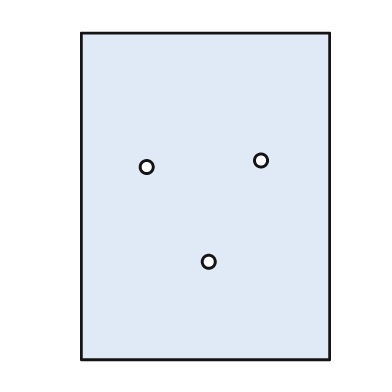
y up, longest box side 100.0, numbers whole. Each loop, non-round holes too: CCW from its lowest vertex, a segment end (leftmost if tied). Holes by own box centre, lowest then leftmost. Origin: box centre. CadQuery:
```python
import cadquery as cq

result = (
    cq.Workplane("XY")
    .moveTo(-38.0, -50.0)
    .lineTo(38.0, -50.0)
    .lineTo(38.0, 50.0)
    .lineTo(-38.0, 50.0)
    .close()
    .moveTo(1.0, -20.0)
    .circle(2.0)
    .moveTo(-18.0, 9.0)
    .circle(2.0)
    .moveTo(17.0, 11.0)
    .circle(2.0)
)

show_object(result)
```